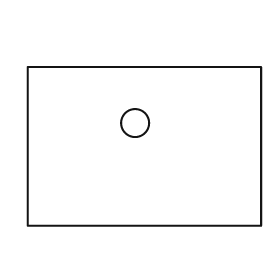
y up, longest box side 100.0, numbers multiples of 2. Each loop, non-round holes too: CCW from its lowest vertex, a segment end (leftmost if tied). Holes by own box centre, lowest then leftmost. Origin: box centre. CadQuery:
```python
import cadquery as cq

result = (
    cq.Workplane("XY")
    .moveTo(-50.0, -34.0)
    .lineTo(50.0, -34.0)
    .lineTo(50.0, 34.0)
    .lineTo(-50.0, 34.0)
    .close()
    .moveTo(-4.0, 10.0)
    .circle(6.0)
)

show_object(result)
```